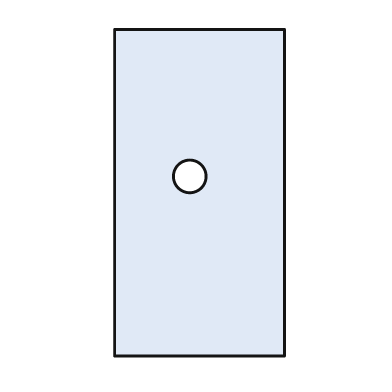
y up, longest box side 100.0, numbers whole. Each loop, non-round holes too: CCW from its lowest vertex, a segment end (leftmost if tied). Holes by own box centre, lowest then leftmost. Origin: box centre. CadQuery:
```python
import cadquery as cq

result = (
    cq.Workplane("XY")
    .moveTo(-26.0, -50.0)
    .lineTo(26.0, -50.0)
    .lineTo(26.0, 50.0)
    .lineTo(-26.0, 50.0)
    .close()
    .moveTo(-3.0, 5.0)
    .circle(5.0)
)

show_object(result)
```